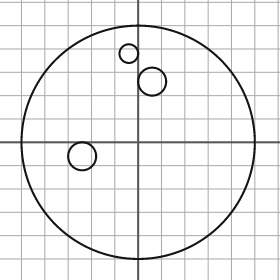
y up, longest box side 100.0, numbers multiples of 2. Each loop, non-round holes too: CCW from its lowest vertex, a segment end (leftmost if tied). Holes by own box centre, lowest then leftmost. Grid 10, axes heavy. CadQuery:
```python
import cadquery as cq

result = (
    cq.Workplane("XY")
    .moveTo(0.0, 0.0)
    .circle(50.0)
    .moveTo(-24.0, -6.0)
    .circle(6.0)
    .moveTo(6.0, 26.0)
    .circle(6.0)
    .moveTo(-4.0, 38.0)
    .circle(4.0)
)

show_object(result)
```